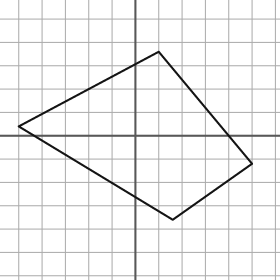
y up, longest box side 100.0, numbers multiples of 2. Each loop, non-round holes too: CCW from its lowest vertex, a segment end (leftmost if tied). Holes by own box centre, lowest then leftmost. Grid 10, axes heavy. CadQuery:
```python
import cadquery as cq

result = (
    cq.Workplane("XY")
    .moveTo(16.0, -36.0)
    .lineTo(50.0, -12.0)
    .lineTo(10.0, 36.0)
    .lineTo(-50.0, 4.0)
    .close()
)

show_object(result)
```